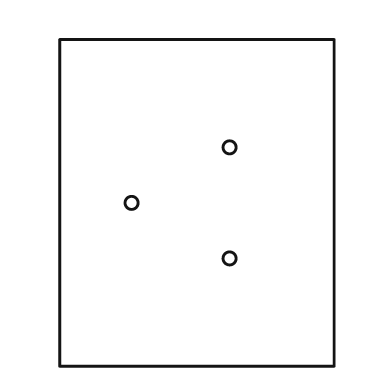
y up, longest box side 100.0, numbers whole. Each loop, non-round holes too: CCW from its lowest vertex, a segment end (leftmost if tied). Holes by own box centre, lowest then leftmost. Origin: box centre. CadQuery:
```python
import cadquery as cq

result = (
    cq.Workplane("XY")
    .moveTo(-42.0, -50.0)
    .lineTo(42.0, -50.0)
    .lineTo(42.0, 50.0)
    .lineTo(-42.0, 50.0)
    .close()
    .moveTo(10.0, -17.0)
    .circle(2.0)
    .moveTo(-20.0, 0.0)
    .circle(2.0)
    .moveTo(10.0, 17.0)
    .circle(2.0)
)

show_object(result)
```